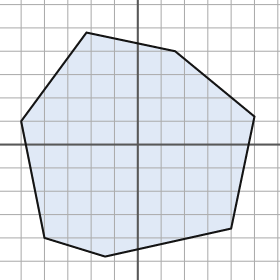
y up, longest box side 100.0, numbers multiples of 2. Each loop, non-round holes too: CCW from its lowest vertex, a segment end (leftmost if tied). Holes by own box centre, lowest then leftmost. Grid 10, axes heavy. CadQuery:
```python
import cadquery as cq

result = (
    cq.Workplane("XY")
    .moveTo(-14.0, -48.0)
    .lineTo(40.0, -36.0)
    .lineTo(50.0, 12.0)
    .lineTo(16.0, 40.0)
    .lineTo(-22.0, 48.0)
    .lineTo(-50.0, 10.0)
    .lineTo(-40.0, -40.0)
    .close()
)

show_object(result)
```